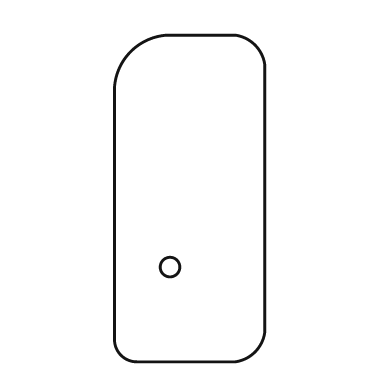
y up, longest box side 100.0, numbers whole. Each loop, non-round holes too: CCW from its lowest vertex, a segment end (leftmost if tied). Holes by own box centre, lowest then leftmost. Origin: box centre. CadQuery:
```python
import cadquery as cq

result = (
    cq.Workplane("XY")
    .moveTo(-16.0, -50.0)
    .lineTo(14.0, -50.0)
    .threePointArc((20.0, -47.0), (23.0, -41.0))
    .lineTo(23.0, 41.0)
    .threePointArc((20.0, 47.0), (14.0, 50.0))
    .lineTo(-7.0, 50.0)
    .threePointArc((-18.0, 45.0), (-23.0, 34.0))
    .lineTo(-23.0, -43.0)
    .threePointArc((-21.0, -48.0), (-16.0, -50.0))
    .close()
    .moveTo(-6.0, -21.0)
    .circle(3.0)
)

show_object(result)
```